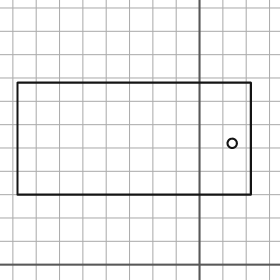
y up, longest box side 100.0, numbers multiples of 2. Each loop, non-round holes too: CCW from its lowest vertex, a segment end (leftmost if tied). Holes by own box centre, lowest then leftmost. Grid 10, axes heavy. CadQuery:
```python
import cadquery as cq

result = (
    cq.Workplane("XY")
    .moveTo(-78.0, 30.0)
    .lineTo(22.0, 30.0)
    .lineTo(22.0, 78.0)
    .lineTo(-78.0, 78.0)
    .close()
    .moveTo(14.0, 52.0)
    .circle(2.0)
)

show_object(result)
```